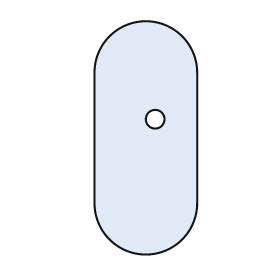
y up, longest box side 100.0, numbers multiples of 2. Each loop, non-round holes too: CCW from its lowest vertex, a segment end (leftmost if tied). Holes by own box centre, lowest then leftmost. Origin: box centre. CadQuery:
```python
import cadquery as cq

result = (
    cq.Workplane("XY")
    .moveTo(-22.0, -28.0)
    .threePointArc((0.0, -50.0), (22.0, -28.0))
    .lineTo(22.0, 28.0)
    .threePointArc((0.0, 50.0), (-22.0, 28.0))
    .close()
    .moveTo(4.0, 8.0)
    .circle(4.0)
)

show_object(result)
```